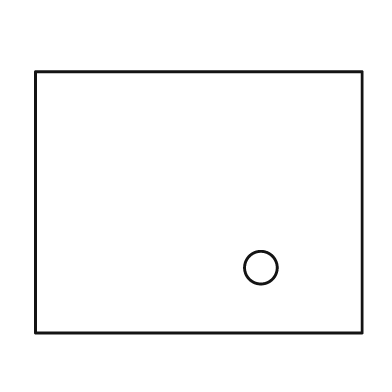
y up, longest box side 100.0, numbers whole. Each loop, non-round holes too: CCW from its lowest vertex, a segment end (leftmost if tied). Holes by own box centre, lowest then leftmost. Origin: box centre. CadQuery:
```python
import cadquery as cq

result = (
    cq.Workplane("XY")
    .moveTo(-50.0, -40.0)
    .lineTo(50.0, -40.0)
    .lineTo(50.0, 40.0)
    .lineTo(-50.0, 40.0)
    .close()
    .moveTo(19.0, -20.0)
    .circle(5.0)
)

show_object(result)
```